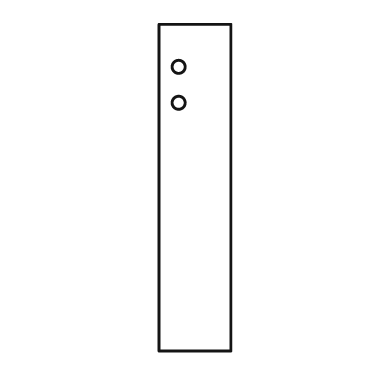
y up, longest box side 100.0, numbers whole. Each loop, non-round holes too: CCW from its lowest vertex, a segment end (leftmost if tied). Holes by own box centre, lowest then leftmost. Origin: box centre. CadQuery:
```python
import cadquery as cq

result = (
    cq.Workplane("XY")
    .moveTo(-11.0, -50.0)
    .lineTo(11.0, -50.0)
    .lineTo(11.0, 50.0)
    .lineTo(-11.0, 50.0)
    .close()
    .moveTo(-5.0, 26.0)
    .circle(2.0)
    .moveTo(-5.0, 37.0)
    .circle(2.0)
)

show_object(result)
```